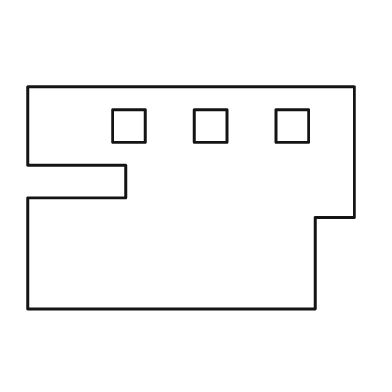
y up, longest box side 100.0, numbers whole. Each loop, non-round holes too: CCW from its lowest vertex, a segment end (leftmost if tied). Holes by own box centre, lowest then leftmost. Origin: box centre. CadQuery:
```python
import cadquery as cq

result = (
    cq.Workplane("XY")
    .moveTo(-50.0, -34.0)
    .lineTo(38.0, -34.0)
    .lineTo(38.0, -6.0)
    .lineTo(50.0, -6.0)
    .lineTo(50.0, 34.0)
    .lineTo(-50.0, 34.0)
    .lineTo(-50.0, 10.0)
    .lineTo(-20.0, 10.0)
    .lineTo(-20.0, 0.0)
    .lineTo(-50.0, 0.0)
    .close()
    .moveTo(-24.0, 17.0)
    .lineTo(-14.0, 17.0)
    .lineTo(-14.0, 27.0)
    .lineTo(-24.0, 27.0)
    .close()
    .moveTo(1.0, 17.0)
    .lineTo(11.0, 17.0)
    .lineTo(11.0, 27.0)
    .lineTo(1.0, 27.0)
    .close()
    .moveTo(26.0, 17.0)
    .lineTo(36.0, 17.0)
    .lineTo(36.0, 27.0)
    .lineTo(26.0, 27.0)
    .close()
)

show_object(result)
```